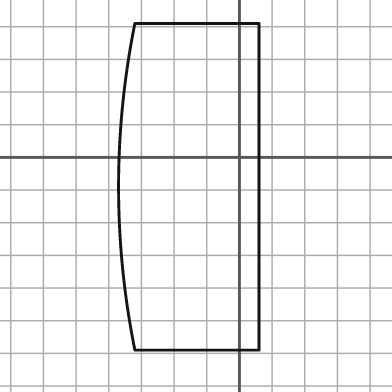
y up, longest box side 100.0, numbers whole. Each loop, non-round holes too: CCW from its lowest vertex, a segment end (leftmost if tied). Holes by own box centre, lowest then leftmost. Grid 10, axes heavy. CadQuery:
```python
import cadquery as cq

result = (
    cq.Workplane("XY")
    .moveTo(-32.0, -59.0)
    .lineTo(6.0, -59.0)
    .lineTo(6.0, 41.0)
    .lineTo(-32.0, 41.0)
    .threePointArc((-37.0, -9.0), (-32.0, -59.0))
    .close()
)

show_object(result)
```